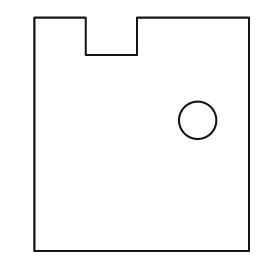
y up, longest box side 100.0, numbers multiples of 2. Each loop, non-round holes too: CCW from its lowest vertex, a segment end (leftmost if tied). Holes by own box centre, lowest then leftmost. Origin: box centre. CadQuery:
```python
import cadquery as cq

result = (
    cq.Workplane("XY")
    .moveTo(-46.0, -50.0)
    .lineTo(46.0, -50.0)
    .lineTo(46.0, 50.0)
    .lineTo(-2.0, 50.0)
    .lineTo(-2.0, 34.0)
    .lineTo(-24.0, 34.0)
    .lineTo(-24.0, 50.0)
    .lineTo(-46.0, 50.0)
    .close()
    .moveTo(24.0, 6.0)
    .circle(8.0)
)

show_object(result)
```